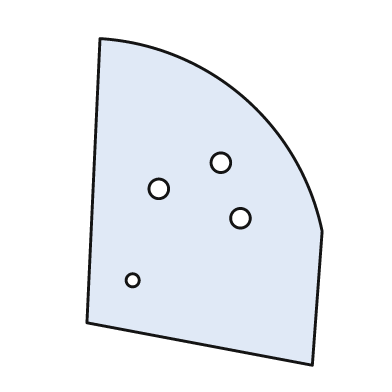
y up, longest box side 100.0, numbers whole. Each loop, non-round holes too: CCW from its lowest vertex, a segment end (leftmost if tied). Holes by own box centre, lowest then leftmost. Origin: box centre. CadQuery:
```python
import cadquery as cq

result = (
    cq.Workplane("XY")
    .moveTo(33.0, -50.0)
    .lineTo(36.0, -9.0)
    .threePointArc((12.0, 32.0), (-32.0, 50.0))
    .lineTo(-36.0, -37.0)
    .close()
    .moveTo(-22.0, -24.0)
    .circle(2.0)
    .moveTo(11.0, -5.0)
    .circle(3.0)
    .moveTo(-14.0, 4.0)
    .circle(3.0)
    .moveTo(5.0, 12.0)
    .circle(3.0)
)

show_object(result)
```